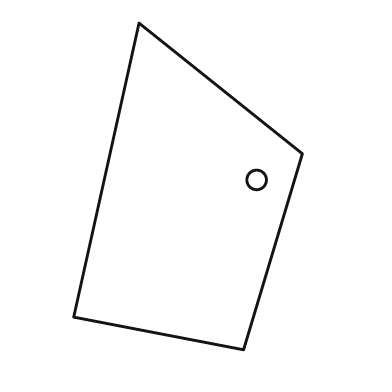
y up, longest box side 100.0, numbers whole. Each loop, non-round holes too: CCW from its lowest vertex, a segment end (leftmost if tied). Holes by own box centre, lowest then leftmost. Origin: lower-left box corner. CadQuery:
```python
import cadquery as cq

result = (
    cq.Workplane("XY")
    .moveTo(52.0, 0.0)
    .lineTo(70.0, 60.0)
    .lineTo(20.0, 100.0)
    .lineTo(0.0, 10.0)
    .close()
    .moveTo(56.0, 52.0)
    .circle(3.0)
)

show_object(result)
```